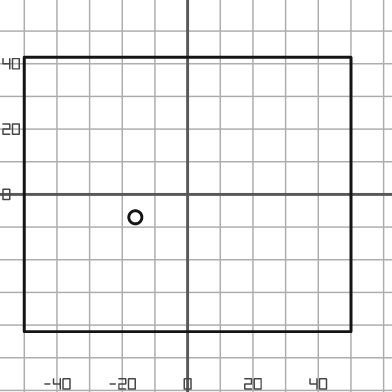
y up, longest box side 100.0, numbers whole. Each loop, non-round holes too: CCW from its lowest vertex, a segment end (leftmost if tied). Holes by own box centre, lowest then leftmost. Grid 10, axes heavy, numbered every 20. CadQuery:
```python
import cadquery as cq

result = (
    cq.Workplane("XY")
    .moveTo(-50.0, -42.0)
    .lineTo(50.0, -42.0)
    .lineTo(50.0, 42.0)
    .lineTo(-50.0, 42.0)
    .close()
    .moveTo(-16.0, -7.0)
    .circle(2.0)
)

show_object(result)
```